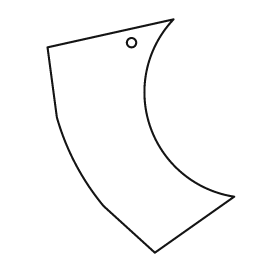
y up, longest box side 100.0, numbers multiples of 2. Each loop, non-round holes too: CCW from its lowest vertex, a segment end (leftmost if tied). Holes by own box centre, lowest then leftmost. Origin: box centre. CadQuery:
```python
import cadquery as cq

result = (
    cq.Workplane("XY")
    .moveTo(6.0, -50.0)
    .lineTo(40.0, -26.0)
    .threePointArc((4.0, 4.0), (14.0, 50.0))
    .lineTo(-40.0, 38.0)
    .lineTo(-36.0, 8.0)
    .threePointArc((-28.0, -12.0), (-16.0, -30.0))
    .close()
    .moveTo(-4.0, 40.0)
    .circle(2.0)
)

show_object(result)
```